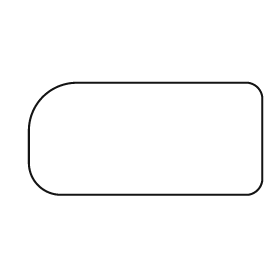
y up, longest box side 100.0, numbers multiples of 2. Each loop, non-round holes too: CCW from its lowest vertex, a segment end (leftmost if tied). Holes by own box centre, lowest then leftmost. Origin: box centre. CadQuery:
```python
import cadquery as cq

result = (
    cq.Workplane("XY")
    .moveTo(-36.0, -24.0)
    .lineTo(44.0, -24.0)
    .threePointArc((48.0, -22.0), (50.0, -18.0))
    .lineTo(50.0, 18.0)
    .threePointArc((48.0, 22.0), (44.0, 24.0))
    .lineTo(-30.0, 24.0)
    .threePointArc((-44.0, 18.0), (-50.0, 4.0))
    .lineTo(-50.0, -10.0)
    .threePointArc((-46.0, -20.0), (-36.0, -24.0))
    .close()
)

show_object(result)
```